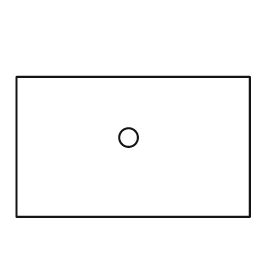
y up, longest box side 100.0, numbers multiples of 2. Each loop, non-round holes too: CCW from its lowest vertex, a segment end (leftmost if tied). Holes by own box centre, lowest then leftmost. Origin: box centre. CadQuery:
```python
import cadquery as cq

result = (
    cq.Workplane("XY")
    .moveTo(-50.0, -30.0)
    .lineTo(50.0, -30.0)
    .lineTo(50.0, 30.0)
    .lineTo(-50.0, 30.0)
    .close()
    .moveTo(-2.0, 4.0)
    .circle(4.0)
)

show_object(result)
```